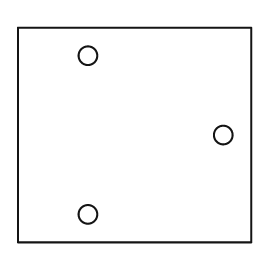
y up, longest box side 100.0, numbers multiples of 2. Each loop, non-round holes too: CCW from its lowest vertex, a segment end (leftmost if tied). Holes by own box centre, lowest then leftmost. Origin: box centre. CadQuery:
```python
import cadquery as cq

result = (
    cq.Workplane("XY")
    .moveTo(-50.0, -46.0)
    .lineTo(50.0, -46.0)
    .lineTo(50.0, 46.0)
    .lineTo(-50.0, 46.0)
    .close()
    .moveTo(-20.0, -34.0)
    .circle(4.0)
    .moveTo(38.0, 0.0)
    .circle(4.0)
    .moveTo(-20.0, 34.0)
    .circle(4.0)
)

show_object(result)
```